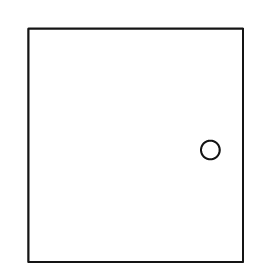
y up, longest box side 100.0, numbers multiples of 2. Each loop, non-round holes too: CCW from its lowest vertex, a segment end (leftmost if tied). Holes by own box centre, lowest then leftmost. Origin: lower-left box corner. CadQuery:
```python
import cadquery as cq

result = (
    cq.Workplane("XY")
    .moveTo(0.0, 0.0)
    .lineTo(92.0, 0.0)
    .lineTo(92.0, 100.0)
    .lineTo(0.0, 100.0)
    .close()
    .moveTo(78.0, 48.0)
    .circle(4.0)
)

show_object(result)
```